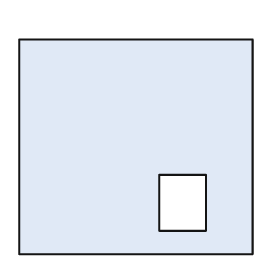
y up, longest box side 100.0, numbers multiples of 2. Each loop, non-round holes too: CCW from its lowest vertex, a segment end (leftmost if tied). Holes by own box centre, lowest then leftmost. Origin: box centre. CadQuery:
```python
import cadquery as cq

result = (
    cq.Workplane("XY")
    .moveTo(-50.0, -46.0)
    .lineTo(50.0, -46.0)
    .lineTo(50.0, 46.0)
    .lineTo(-50.0, 46.0)
    .close()
    .moveTo(10.0, -36.0)
    .lineTo(30.0, -36.0)
    .lineTo(30.0, -12.0)
    .lineTo(10.0, -12.0)
    .close()
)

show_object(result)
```